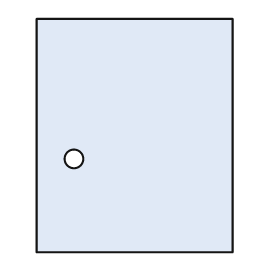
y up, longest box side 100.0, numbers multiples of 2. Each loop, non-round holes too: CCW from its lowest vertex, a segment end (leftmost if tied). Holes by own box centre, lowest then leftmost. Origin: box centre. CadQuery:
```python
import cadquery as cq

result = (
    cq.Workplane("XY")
    .moveTo(-42.0, -50.0)
    .lineTo(42.0, -50.0)
    .lineTo(42.0, 50.0)
    .lineTo(-42.0, 50.0)
    .close()
    .moveTo(-26.0, -10.0)
    .circle(4.0)
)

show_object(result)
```